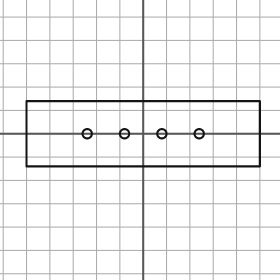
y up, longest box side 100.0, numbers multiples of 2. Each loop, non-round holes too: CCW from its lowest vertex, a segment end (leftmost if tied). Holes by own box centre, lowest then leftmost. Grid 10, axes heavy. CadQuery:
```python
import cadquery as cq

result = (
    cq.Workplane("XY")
    .moveTo(-50.0, -14.0)
    .lineTo(50.0, -14.0)
    .lineTo(50.0, 14.0)
    .lineTo(-50.0, 14.0)
    .close()
    .moveTo(-24.0, 0.0)
    .circle(2.0)
    .moveTo(-8.0, 0.0)
    .circle(2.0)
    .moveTo(8.0, 0.0)
    .circle(2.0)
    .moveTo(24.0, 0.0)
    .circle(2.0)
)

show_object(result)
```